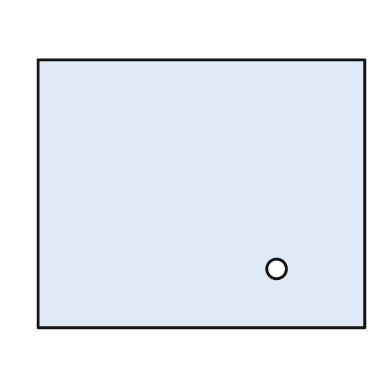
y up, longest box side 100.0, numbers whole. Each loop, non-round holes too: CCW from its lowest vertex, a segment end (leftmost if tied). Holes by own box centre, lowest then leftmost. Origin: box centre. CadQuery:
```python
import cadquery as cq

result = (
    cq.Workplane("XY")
    .moveTo(-50.0, -41.0)
    .lineTo(50.0, -41.0)
    .lineTo(50.0, 41.0)
    .lineTo(-50.0, 41.0)
    .close()
    .moveTo(23.0, -23.0)
    .circle(3.0)
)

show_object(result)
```